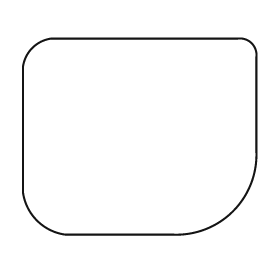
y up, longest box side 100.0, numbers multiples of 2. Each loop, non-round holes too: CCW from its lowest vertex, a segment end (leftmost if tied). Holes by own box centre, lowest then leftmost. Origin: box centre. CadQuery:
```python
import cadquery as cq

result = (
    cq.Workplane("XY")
    .moveTo(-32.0, -42.0)
    .lineTo(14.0, -42.0)
    .threePointArc((40.0, -32.0), (50.0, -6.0))
    .lineTo(50.0, 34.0)
    .threePointArc((48.0, 40.0), (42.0, 42.0))
    .lineTo(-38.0, 42.0)
    .threePointArc((-46.0, 38.0), (-50.0, 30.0))
    .lineTo(-50.0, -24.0)
    .threePointArc((-44.0, -36.0), (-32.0, -42.0))
    .close()
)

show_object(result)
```